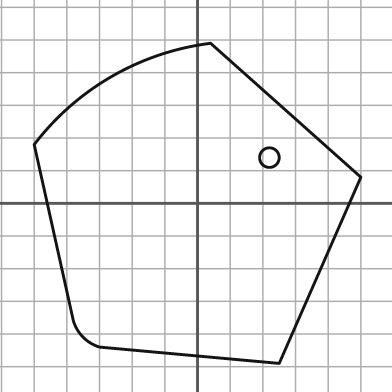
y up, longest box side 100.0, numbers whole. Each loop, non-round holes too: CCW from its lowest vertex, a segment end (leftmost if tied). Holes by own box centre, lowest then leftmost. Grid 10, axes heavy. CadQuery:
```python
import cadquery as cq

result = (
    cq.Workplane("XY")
    .moveTo(25.0, -49.0)
    .lineTo(50.0, 8.0)
    .lineTo(4.0, 49.0)
    .threePointArc((-26.0, 39.0), (-50.0, 18.0))
    .lineTo(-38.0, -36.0)
    .threePointArc((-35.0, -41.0), (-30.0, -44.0))
    .close()
    .moveTo(22.0, 14.0)
    .circle(3.0)
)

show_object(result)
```